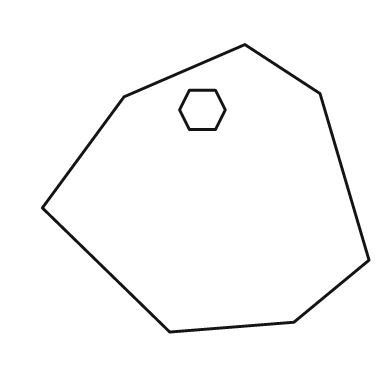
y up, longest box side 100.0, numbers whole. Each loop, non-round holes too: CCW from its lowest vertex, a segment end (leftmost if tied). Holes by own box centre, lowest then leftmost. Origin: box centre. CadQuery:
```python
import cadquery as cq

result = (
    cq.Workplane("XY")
    .moveTo(-11.0, -44.0)
    .lineTo(27.0, -41.0)
    .lineTo(50.0, -22.0)
    .lineTo(35.0, 29.0)
    .lineTo(12.0, 44.0)
    .lineTo(-25.0, 28.0)
    .lineTo(-50.0, -6.0)
    .close()
    .moveTo(-5.0, 18.0)
    .lineTo(3.0, 18.0)
    .lineTo(6.0, 24.0)
    .lineTo(3.0, 30.0)
    .lineTo(-5.0, 30.0)
    .lineTo(-8.0, 24.0)
    .close()
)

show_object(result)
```